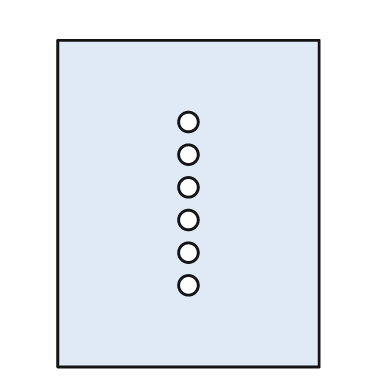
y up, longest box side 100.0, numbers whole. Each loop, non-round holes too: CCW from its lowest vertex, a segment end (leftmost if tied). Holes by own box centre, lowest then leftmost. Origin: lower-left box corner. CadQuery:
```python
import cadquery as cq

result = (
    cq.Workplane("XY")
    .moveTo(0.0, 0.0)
    .lineTo(80.0, 0.0)
    .lineTo(80.0, 100.0)
    .lineTo(0.0, 100.0)
    .close()
    .moveTo(40.0, 25.0)
    .circle(3.0)
    .moveTo(40.0, 35.0)
    .circle(3.0)
    .moveTo(40.0, 45.0)
    .circle(3.0)
    .moveTo(40.0, 55.0)
    .circle(3.0)
    .moveTo(40.0, 65.0)
    .circle(3.0)
    .moveTo(40.0, 75.0)
    .circle(3.0)
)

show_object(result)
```